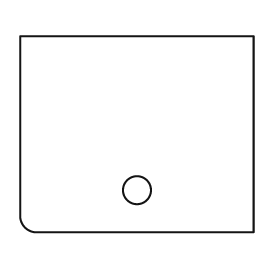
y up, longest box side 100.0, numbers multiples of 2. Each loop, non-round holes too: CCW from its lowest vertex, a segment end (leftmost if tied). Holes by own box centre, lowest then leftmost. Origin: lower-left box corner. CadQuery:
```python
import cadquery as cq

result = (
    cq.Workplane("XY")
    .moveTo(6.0, 0.0)
    .lineTo(100.0, 0.0)
    .lineTo(100.0, 84.0)
    .lineTo(0.0, 84.0)
    .lineTo(0.0, 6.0)
    .threePointArc((2.0, 2.0), (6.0, 0.0))
    .close()
    .moveTo(50.0, 18.0)
    .circle(6.0)
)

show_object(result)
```